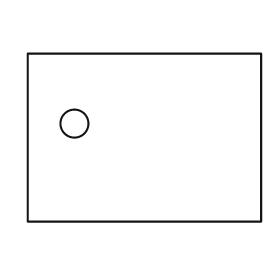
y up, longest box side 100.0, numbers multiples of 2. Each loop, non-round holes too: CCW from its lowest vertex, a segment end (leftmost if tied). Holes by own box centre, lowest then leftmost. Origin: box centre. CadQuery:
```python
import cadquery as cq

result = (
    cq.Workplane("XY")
    .moveTo(-50.0, -36.0)
    .lineTo(50.0, -36.0)
    .lineTo(50.0, 36.0)
    .lineTo(-50.0, 36.0)
    .close()
    .moveTo(-30.0, 6.0)
    .circle(6.0)
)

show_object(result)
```